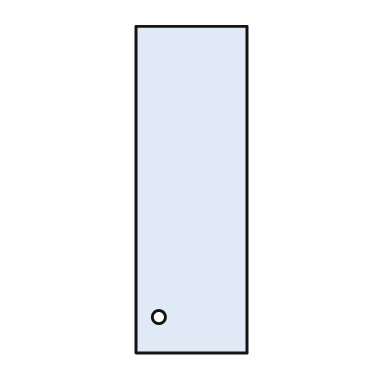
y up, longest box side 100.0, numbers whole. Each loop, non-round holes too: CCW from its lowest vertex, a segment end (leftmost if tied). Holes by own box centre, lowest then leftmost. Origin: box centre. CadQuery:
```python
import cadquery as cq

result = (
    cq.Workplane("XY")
    .moveTo(-17.0, -50.0)
    .lineTo(17.0, -50.0)
    .lineTo(17.0, 50.0)
    .lineTo(-17.0, 50.0)
    .close()
    .moveTo(-10.0, -39.0)
    .circle(2.0)
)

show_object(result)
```